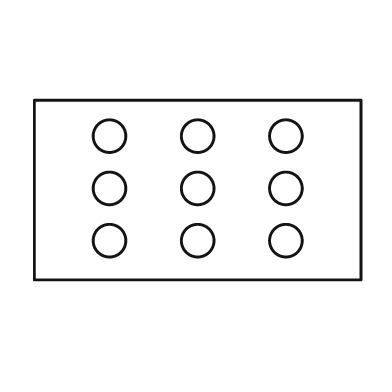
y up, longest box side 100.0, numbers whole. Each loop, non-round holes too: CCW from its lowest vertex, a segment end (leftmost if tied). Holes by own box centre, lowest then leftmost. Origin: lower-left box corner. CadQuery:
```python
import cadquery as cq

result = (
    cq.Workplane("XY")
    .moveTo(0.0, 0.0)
    .lineTo(100.0, 0.0)
    .lineTo(100.0, 55.0)
    .lineTo(0.0, 55.0)
    .close()
    .moveTo(23.0, 12.0)
    .circle(5.0)
    .moveTo(50.0, 12.0)
    .circle(5.0)
    .moveTo(77.0, 12.0)
    .circle(5.0)
    .moveTo(23.0, 28.0)
    .circle(5.0)
    .moveTo(50.0, 28.0)
    .circle(5.0)
    .moveTo(77.0, 28.0)
    .circle(5.0)
    .moveTo(23.0, 44.0)
    .circle(5.0)
    .moveTo(50.0, 44.0)
    .circle(5.0)
    .moveTo(77.0, 44.0)
    .circle(5.0)
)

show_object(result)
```